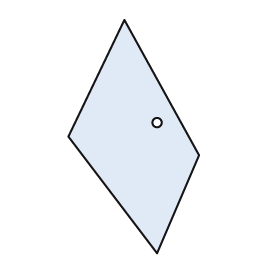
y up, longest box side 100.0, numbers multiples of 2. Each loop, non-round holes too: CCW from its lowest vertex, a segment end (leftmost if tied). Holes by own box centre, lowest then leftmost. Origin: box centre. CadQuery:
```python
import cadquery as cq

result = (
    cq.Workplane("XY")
    .moveTo(10.0, -50.0)
    .lineTo(28.0, -8.0)
    .lineTo(-4.0, 50.0)
    .lineTo(-28.0, 0.0)
    .close()
    .moveTo(10.0, 6.0)
    .circle(2.0)
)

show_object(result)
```